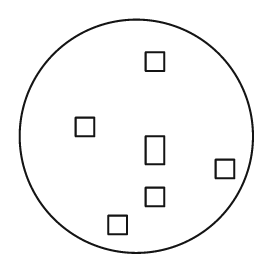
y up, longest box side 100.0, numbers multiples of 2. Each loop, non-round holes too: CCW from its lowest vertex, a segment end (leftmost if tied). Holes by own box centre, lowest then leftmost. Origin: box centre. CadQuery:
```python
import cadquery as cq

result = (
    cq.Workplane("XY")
    .moveTo(0.0, 0.0)
    .circle(50.0)
    .moveTo(-12.0, -42.0)
    .lineTo(-4.0, -42.0)
    .lineTo(-4.0, -34.0)
    .lineTo(-12.0, -34.0)
    .close()
    .moveTo(4.0, -30.0)
    .lineTo(12.0, -30.0)
    .lineTo(12.0, -22.0)
    .lineTo(4.0, -22.0)
    .close()
    .moveTo(34.0, -18.0)
    .lineTo(42.0, -18.0)
    .lineTo(42.0, -10.0)
    .lineTo(34.0, -10.0)
    .close()
    .moveTo(4.0, -12.0)
    .lineTo(12.0, -12.0)
    .lineTo(12.0, 0.0)
    .lineTo(4.0, 0.0)
    .close()
    .moveTo(-26.0, 0.0)
    .lineTo(-18.0, 0.0)
    .lineTo(-18.0, 8.0)
    .lineTo(-26.0, 8.0)
    .close()
    .moveTo(4.0, 28.0)
    .lineTo(12.0, 28.0)
    .lineTo(12.0, 36.0)
    .lineTo(4.0, 36.0)
    .close()
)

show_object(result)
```